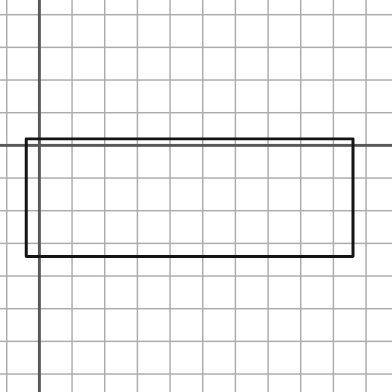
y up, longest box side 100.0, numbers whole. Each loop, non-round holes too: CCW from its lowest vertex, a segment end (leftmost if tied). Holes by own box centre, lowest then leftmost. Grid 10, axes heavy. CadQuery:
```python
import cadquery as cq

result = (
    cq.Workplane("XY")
    .moveTo(-4.0, -34.0)
    .lineTo(96.0, -34.0)
    .lineTo(96.0, 2.0)
    .lineTo(-4.0, 2.0)
    .close()
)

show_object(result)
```